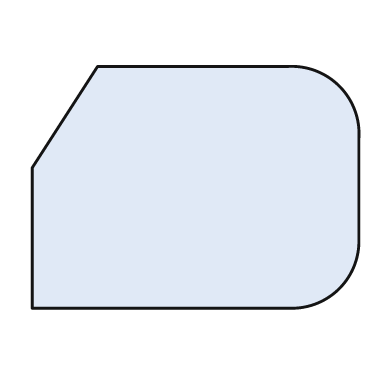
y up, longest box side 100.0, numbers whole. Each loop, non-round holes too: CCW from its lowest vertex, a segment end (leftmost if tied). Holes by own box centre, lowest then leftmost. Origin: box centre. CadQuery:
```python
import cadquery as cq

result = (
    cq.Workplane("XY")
    .moveTo(-50.0, -37.0)
    .lineTo(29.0, -37.0)
    .threePointArc((44.0, -31.0), (50.0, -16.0))
    .lineTo(50.0, 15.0)
    .threePointArc((44.0, 31.0), (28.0, 37.0))
    .lineTo(-30.0, 37.0)
    .lineTo(-50.0, 6.0)
    .close()
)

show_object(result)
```